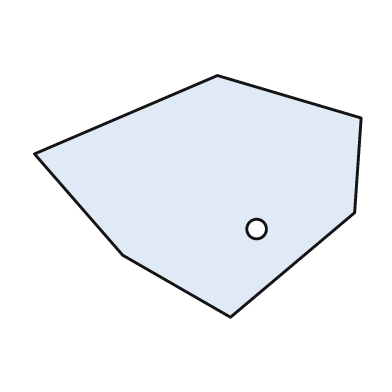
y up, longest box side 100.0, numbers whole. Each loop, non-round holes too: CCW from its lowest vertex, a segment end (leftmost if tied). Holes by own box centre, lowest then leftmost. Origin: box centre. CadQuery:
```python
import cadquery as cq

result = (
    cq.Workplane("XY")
    .moveTo(10.0, -37.0)
    .lineTo(48.0, -5.0)
    .lineTo(50.0, 24.0)
    .lineTo(6.0, 37.0)
    .lineTo(-50.0, 13.0)
    .lineTo(-23.0, -18.0)
    .close()
    .moveTo(18.0, -10.0)
    .circle(3.0)
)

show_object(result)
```